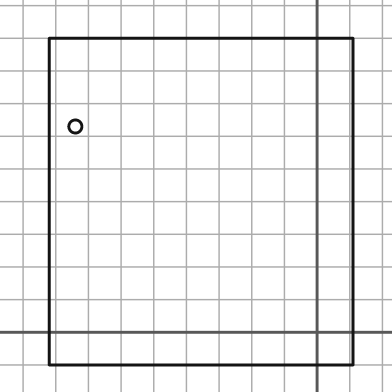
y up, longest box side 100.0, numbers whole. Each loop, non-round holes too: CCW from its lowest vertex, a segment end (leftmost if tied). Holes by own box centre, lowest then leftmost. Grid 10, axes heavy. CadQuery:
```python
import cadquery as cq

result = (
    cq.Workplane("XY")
    .moveTo(-82.0, -10.0)
    .lineTo(11.0, -10.0)
    .lineTo(11.0, 90.0)
    .lineTo(-82.0, 90.0)
    .close()
    .moveTo(-74.0, 63.0)
    .circle(2.0)
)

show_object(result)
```